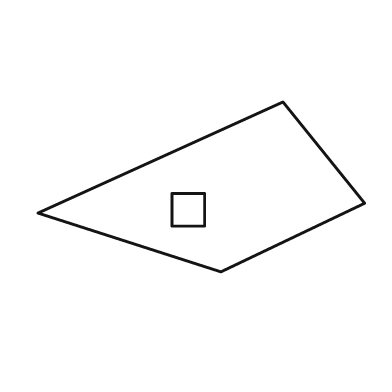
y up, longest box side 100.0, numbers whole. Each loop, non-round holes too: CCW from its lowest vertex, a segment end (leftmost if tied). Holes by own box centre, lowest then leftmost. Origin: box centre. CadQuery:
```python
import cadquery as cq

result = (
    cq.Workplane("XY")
    .moveTo(6.0, -26.0)
    .lineTo(50.0, -5.0)
    .lineTo(25.0, 26.0)
    .lineTo(-50.0, -8.0)
    .close()
    .moveTo(-9.0, -12.0)
    .lineTo(1.0, -12.0)
    .lineTo(1.0, -2.0)
    .lineTo(-9.0, -2.0)
    .close()
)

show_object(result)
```